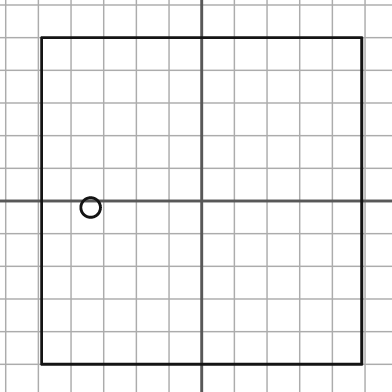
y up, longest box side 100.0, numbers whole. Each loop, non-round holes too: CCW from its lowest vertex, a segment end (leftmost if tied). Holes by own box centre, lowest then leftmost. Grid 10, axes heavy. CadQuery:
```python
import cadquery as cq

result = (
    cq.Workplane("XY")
    .moveTo(-49.0, -50.0)
    .lineTo(49.0, -50.0)
    .lineTo(49.0, 50.0)
    .lineTo(-49.0, 50.0)
    .close()
    .moveTo(-34.0, -2.0)
    .circle(3.0)
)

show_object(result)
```